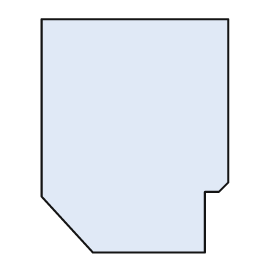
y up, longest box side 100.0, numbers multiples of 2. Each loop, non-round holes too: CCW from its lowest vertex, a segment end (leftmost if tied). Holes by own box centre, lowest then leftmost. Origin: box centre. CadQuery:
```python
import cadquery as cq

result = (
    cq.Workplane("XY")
    .moveTo(-18.0, -50.0)
    .lineTo(30.0, -50.0)
    .lineTo(30.0, -24.0)
    .lineTo(36.0, -24.0)
    .lineTo(40.0, -20.0)
    .lineTo(40.0, 50.0)
    .lineTo(-40.0, 50.0)
    .lineTo(-40.0, -26.0)
    .close()
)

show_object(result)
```